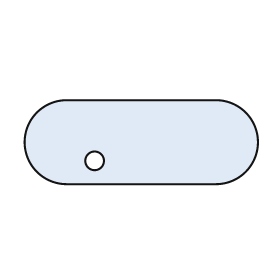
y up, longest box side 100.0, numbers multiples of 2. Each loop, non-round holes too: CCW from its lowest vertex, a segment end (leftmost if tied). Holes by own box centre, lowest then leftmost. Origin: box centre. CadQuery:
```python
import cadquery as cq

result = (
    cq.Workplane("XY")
    .moveTo(-32.0, -18.0)
    .lineTo(32.0, -18.0)
    .threePointArc((50.0, 0.0), (32.0, 18.0))
    .lineTo(-32.0, 18.0)
    .threePointArc((-50.0, 0.0), (-32.0, -18.0))
    .close()
    .moveTo(-20.0, -8.0)
    .circle(4.0)
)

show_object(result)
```